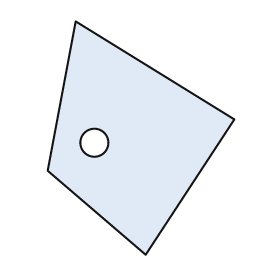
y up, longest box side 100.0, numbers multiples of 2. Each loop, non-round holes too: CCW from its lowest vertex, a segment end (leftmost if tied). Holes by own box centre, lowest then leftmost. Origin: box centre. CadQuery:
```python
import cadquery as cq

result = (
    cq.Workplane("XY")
    .moveTo(2.0, -50.0)
    .lineTo(40.0, 8.0)
    .lineTo(-28.0, 50.0)
    .lineTo(-40.0, -14.0)
    .close()
    .moveTo(-20.0, -2.0)
    .circle(6.0)
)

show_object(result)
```